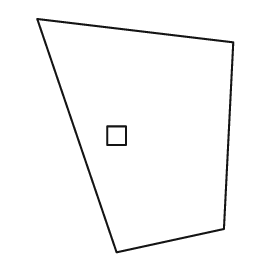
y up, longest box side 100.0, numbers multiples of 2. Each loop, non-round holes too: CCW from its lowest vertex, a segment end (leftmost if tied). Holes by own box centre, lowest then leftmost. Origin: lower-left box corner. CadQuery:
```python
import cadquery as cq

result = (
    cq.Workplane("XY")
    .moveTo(34.0, 0.0)
    .lineTo(80.0, 10.0)
    .lineTo(84.0, 90.0)
    .lineTo(0.0, 100.0)
    .close()
    .moveTo(30.0, 46.0)
    .lineTo(38.0, 46.0)
    .lineTo(38.0, 54.0)
    .lineTo(30.0, 54.0)
    .close()
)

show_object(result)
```